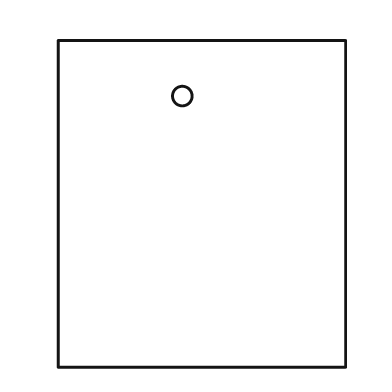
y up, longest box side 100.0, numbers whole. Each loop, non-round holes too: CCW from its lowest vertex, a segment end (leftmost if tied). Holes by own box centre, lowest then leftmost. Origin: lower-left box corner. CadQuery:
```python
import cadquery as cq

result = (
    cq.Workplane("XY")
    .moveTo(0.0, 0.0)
    .lineTo(88.0, 0.0)
    .lineTo(88.0, 100.0)
    .lineTo(0.0, 100.0)
    .close()
    .moveTo(38.0, 83.0)
    .circle(3.0)
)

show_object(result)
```